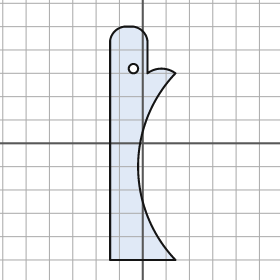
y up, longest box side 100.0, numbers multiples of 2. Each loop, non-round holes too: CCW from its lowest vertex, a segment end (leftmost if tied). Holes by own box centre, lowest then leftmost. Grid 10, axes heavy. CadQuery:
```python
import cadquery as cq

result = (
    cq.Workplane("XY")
    .moveTo(-14.0, -50.0)
    .lineTo(14.0, -50.0)
    .threePointArc((-2.0, -10.0), (14.0, 30.0))
    .threePointArc((8.0, 32.0), (2.0, 30.0))
    .lineTo(2.0, 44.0)
    .threePointArc((0.0, 48.0), (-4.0, 50.0))
    .lineTo(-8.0, 50.0)
    .threePointArc((-12.0, 48.0), (-14.0, 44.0))
    .close()
    .moveTo(-4.0, 32.0)
    .circle(2.0)
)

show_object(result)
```